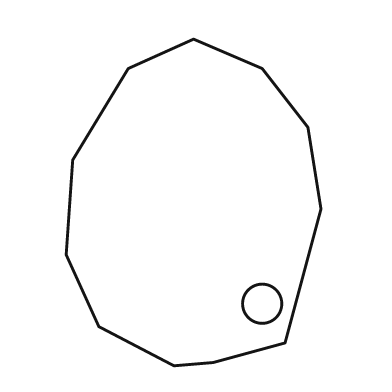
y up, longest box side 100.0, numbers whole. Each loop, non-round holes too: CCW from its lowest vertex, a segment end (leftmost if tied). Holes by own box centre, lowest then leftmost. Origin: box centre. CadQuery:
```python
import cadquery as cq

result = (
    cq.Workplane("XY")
    .moveTo(-6.0, -50.0)
    .lineTo(6.0, -49.0)
    .lineTo(28.0, -43.0)
    .lineTo(39.0, -2.0)
    .lineTo(35.0, 23.0)
    .lineTo(21.0, 41.0)
    .lineTo(0.0, 50.0)
    .lineTo(-20.0, 41.0)
    .lineTo(-37.0, 13.0)
    .lineTo(-39.0, -16.0)
    .lineTo(-29.0, -38.0)
    .close()
    .moveTo(21.0, -31.0)
    .circle(6.0)
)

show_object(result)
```